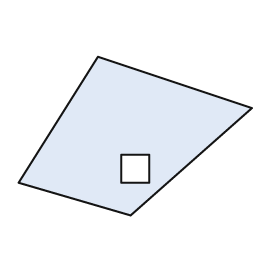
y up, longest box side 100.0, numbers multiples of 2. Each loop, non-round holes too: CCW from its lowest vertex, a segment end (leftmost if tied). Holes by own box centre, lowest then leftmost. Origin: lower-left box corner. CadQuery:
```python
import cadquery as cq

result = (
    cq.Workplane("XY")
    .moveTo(48.0, 0.0)
    .lineTo(100.0, 46.0)
    .lineTo(34.0, 68.0)
    .lineTo(0.0, 14.0)
    .close()
    .moveTo(44.0, 14.0)
    .lineTo(56.0, 14.0)
    .lineTo(56.0, 26.0)
    .lineTo(44.0, 26.0)
    .close()
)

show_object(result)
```